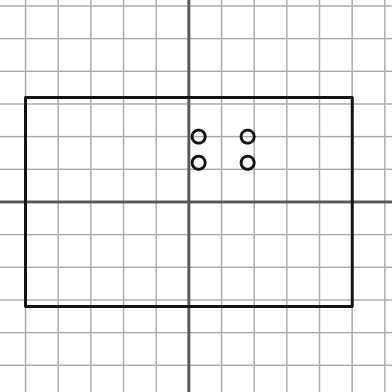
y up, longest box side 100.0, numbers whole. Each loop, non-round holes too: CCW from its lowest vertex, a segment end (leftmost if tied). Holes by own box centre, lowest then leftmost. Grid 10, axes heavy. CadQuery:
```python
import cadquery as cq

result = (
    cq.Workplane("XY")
    .moveTo(-50.0, -32.0)
    .lineTo(50.0, -32.0)
    .lineTo(50.0, 32.0)
    .lineTo(-50.0, 32.0)
    .close()
    .moveTo(3.0, 12.0)
    .circle(2.0)
    .moveTo(18.0, 12.0)
    .circle(2.0)
    .moveTo(3.0, 20.0)
    .circle(2.0)
    .moveTo(18.0, 20.0)
    .circle(2.0)
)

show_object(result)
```